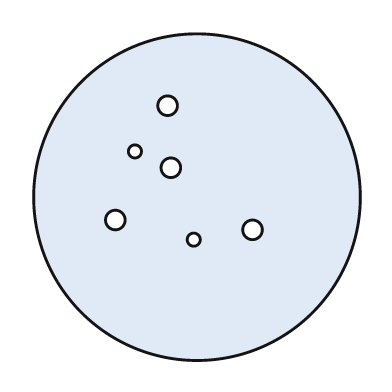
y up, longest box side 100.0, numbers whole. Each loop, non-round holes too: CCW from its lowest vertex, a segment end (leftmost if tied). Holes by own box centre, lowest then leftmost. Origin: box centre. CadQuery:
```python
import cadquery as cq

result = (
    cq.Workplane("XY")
    .moveTo(0.0, 0.0)
    .circle(50.0)
    .moveTo(-1.0, -13.0)
    .circle(2.0)
    .moveTo(17.0, -10.0)
    .circle(3.0)
    .moveTo(-25.0, -7.0)
    .circle(3.0)
    .moveTo(-8.0, 9.0)
    .circle(3.0)
    .moveTo(-19.0, 14.0)
    .circle(2.0)
    .moveTo(-9.0, 28.0)
    .circle(3.0)
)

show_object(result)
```